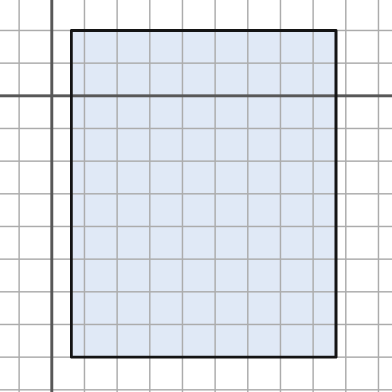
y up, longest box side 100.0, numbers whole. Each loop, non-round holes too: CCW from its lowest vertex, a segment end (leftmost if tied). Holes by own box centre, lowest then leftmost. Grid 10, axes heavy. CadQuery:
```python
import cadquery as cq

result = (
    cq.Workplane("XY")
    .moveTo(6.0, -80.0)
    .lineTo(87.0, -80.0)
    .lineTo(87.0, 20.0)
    .lineTo(6.0, 20.0)
    .close()
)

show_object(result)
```